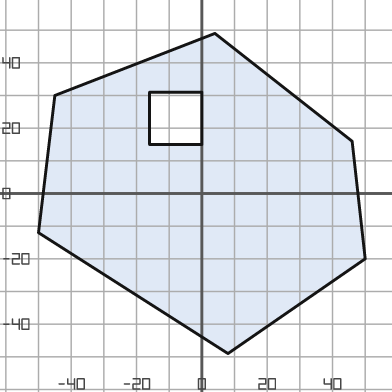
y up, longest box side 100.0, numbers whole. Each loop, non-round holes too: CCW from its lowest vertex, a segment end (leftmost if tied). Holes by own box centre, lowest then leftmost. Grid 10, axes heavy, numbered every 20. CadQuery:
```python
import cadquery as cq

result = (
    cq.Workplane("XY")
    .moveTo(8.0, -49.0)
    .lineTo(50.0, -20.0)
    .lineTo(46.0, 16.0)
    .lineTo(4.0, 49.0)
    .lineTo(-45.0, 30.0)
    .lineTo(-50.0, -12.0)
    .close()
    .moveTo(-16.0, 15.0)
    .lineTo(0.0, 15.0)
    .lineTo(0.0, 31.0)
    .lineTo(-16.0, 31.0)
    .close()
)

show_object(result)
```